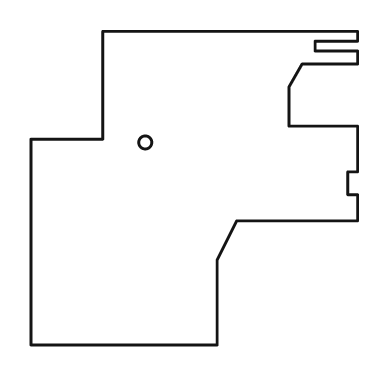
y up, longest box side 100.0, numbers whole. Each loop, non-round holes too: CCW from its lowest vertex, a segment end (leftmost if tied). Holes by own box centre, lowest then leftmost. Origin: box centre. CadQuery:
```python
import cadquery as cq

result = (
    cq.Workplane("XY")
    .moveTo(-50.0, -48.0)
    .lineTo(7.0, -48.0)
    .lineTo(7.0, -22.0)
    .lineTo(13.0, -10.0)
    .lineTo(50.0, -10.0)
    .lineTo(50.0, -2.0)
    .lineTo(47.0, -2.0)
    .lineTo(47.0, 5.0)
    .lineTo(50.0, 5.0)
    .lineTo(50.0, 19.0)
    .lineTo(29.0, 19.0)
    .lineTo(29.0, 31.0)
    .lineTo(33.0, 38.0)
    .lineTo(50.0, 38.0)
    .lineTo(50.0, 42.0)
    .lineTo(37.0, 42.0)
    .lineTo(37.0, 45.0)
    .lineTo(50.0, 45.0)
    .lineTo(50.0, 48.0)
    .lineTo(-28.0, 48.0)
    .lineTo(-28.0, 15.0)
    .lineTo(-50.0, 15.0)
    .close()
    .moveTo(-15.0, 14.0)
    .circle(2.0)
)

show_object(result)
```